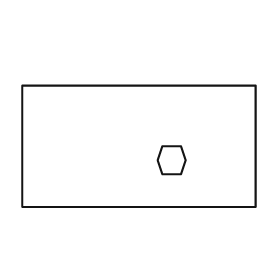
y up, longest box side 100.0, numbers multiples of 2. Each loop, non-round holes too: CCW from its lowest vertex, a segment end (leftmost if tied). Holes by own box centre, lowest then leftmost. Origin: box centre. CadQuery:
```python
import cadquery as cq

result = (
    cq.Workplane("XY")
    .moveTo(-50.0, -26.0)
    .lineTo(50.0, -26.0)
    .lineTo(50.0, 26.0)
    .lineTo(-50.0, 26.0)
    .close()
    .moveTo(10.0, -12.0)
    .lineTo(18.0, -12.0)
    .lineTo(20.0, -6.0)
    .lineTo(18.0, 0.0)
    .lineTo(10.0, 0.0)
    .lineTo(8.0, -6.0)
    .close()
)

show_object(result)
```